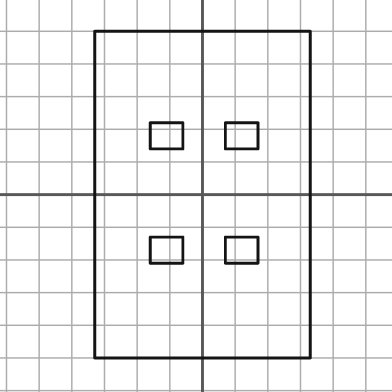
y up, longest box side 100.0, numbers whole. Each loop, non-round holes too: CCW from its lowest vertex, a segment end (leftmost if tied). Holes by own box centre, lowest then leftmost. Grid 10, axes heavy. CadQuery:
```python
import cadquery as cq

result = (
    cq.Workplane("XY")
    .moveTo(-33.0, -50.0)
    .lineTo(33.0, -50.0)
    .lineTo(33.0, 50.0)
    .lineTo(-33.0, 50.0)
    .close()
    .moveTo(-16.0, -21.0)
    .lineTo(-6.0, -21.0)
    .lineTo(-6.0, -13.0)
    .lineTo(-16.0, -13.0)
    .close()
    .moveTo(7.0, -21.0)
    .lineTo(17.0, -21.0)
    .lineTo(17.0, -13.0)
    .lineTo(7.0, -13.0)
    .close()
    .moveTo(-16.0, 14.0)
    .lineTo(-6.0, 14.0)
    .lineTo(-6.0, 22.0)
    .lineTo(-16.0, 22.0)
    .close()
    .moveTo(7.0, 14.0)
    .lineTo(17.0, 14.0)
    .lineTo(17.0, 22.0)
    .lineTo(7.0, 22.0)
    .close()
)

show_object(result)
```